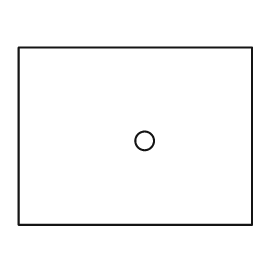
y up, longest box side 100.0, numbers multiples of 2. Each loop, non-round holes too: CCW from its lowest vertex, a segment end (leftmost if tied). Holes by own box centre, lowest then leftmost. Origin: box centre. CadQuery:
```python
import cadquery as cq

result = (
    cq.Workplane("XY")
    .moveTo(-50.0, -38.0)
    .lineTo(50.0, -38.0)
    .lineTo(50.0, 38.0)
    .lineTo(-50.0, 38.0)
    .close()
    .moveTo(4.0, -2.0)
    .circle(4.0)
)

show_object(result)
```